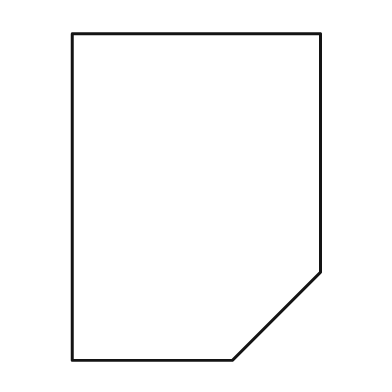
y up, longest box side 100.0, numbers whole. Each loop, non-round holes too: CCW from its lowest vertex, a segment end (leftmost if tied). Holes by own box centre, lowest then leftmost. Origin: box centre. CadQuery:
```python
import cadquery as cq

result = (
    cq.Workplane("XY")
    .moveTo(-38.0, -50.0)
    .lineTo(11.0, -50.0)
    .lineTo(38.0, -23.0)
    .lineTo(38.0, 50.0)
    .lineTo(-38.0, 50.0)
    .close()
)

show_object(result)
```